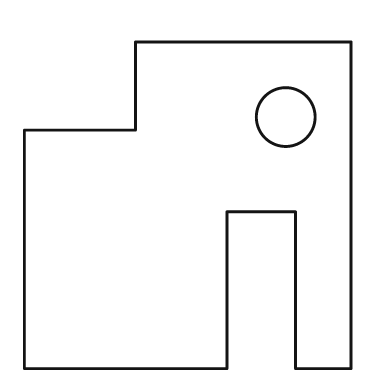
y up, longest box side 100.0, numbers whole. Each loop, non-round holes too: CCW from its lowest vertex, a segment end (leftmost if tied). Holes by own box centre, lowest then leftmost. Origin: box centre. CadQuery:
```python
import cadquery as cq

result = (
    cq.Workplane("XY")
    .moveTo(-50.0, -50.0)
    .lineTo(12.0, -50.0)
    .lineTo(12.0, -2.0)
    .lineTo(33.0, -2.0)
    .lineTo(33.0, -50.0)
    .lineTo(50.0, -50.0)
    .lineTo(50.0, 50.0)
    .lineTo(-16.0, 50.0)
    .lineTo(-16.0, 23.0)
    .lineTo(-50.0, 23.0)
    .close()
    .moveTo(30.0, 27.0)
    .circle(9.0)
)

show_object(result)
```